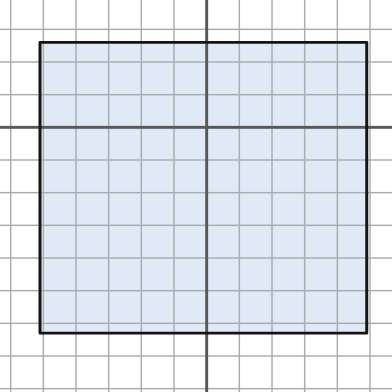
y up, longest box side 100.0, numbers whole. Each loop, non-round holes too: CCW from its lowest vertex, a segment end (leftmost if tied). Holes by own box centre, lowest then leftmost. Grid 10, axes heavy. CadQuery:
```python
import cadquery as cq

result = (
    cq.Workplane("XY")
    .moveTo(-51.0, -63.0)
    .lineTo(49.0, -63.0)
    .lineTo(49.0, 26.0)
    .lineTo(-51.0, 26.0)
    .close()
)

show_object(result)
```